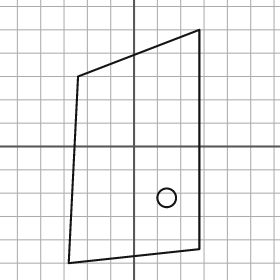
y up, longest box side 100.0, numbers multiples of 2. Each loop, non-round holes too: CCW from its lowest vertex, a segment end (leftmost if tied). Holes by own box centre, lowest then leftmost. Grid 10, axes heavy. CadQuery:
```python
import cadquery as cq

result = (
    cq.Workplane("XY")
    .moveTo(-28.0, -50.0)
    .lineTo(28.0, -44.0)
    .lineTo(28.0, 50.0)
    .lineTo(-24.0, 30.0)
    .close()
    .moveTo(14.0, -22.0)
    .circle(4.0)
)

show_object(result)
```